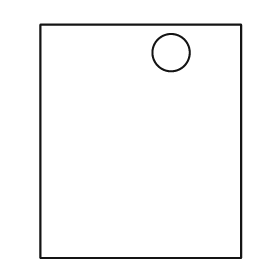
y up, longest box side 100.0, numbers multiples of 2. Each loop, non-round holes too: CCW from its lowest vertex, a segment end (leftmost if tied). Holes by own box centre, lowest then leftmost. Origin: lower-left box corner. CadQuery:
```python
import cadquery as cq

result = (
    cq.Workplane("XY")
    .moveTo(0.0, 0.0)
    .lineTo(86.0, 0.0)
    .lineTo(86.0, 100.0)
    .lineTo(0.0, 100.0)
    .close()
    .moveTo(56.0, 88.0)
    .circle(8.0)
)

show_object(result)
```